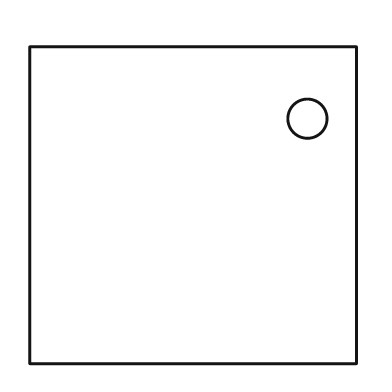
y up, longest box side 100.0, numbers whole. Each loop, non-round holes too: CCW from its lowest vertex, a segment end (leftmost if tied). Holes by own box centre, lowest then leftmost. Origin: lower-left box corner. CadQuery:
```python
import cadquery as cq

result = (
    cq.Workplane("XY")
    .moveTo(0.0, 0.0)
    .lineTo(100.0, 0.0)
    .lineTo(100.0, 97.0)
    .lineTo(0.0, 97.0)
    .close()
    .moveTo(85.0, 75.0)
    .circle(6.0)
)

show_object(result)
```